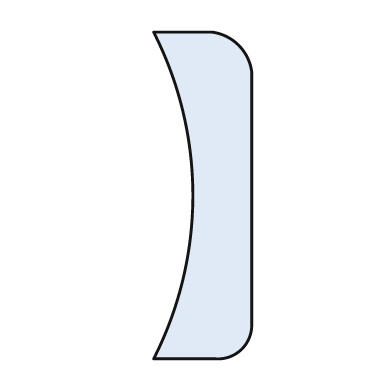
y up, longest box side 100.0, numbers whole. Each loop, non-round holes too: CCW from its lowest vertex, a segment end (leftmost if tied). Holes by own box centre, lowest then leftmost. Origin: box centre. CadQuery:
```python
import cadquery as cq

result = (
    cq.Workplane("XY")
    .moveTo(-15.0, -50.0)
    .lineTo(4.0, -50.0)
    .threePointArc((12.0, -47.0), (15.0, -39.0))
    .lineTo(15.0, 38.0)
    .threePointArc((11.0, 46.0), (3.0, 50.0))
    .lineTo(-15.0, 50.0)
    .threePointArc((-3.0, 0.0), (-15.0, -50.0))
    .close()
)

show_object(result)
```